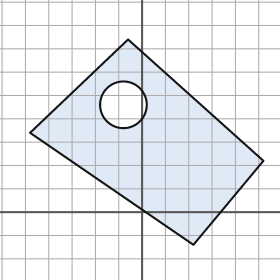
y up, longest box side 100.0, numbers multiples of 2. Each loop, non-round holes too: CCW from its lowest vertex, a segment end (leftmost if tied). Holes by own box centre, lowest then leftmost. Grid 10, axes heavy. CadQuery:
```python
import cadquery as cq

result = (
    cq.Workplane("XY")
    .moveTo(22.0, -14.0)
    .lineTo(52.0, 22.0)
    .lineTo(-6.0, 74.0)
    .lineTo(-48.0, 34.0)
    .close()
    .moveTo(-8.0, 46.0)
    .circle(10.0)
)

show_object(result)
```